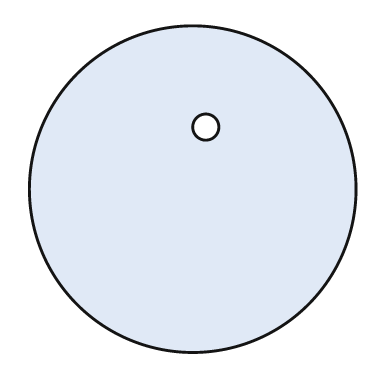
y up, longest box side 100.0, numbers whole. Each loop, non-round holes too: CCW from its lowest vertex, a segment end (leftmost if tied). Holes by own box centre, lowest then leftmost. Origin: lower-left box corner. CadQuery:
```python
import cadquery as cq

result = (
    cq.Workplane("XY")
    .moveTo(50.0, 50.0)
    .circle(50.0)
    .moveTo(54.0, 69.0)
    .circle(4.0)
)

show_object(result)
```